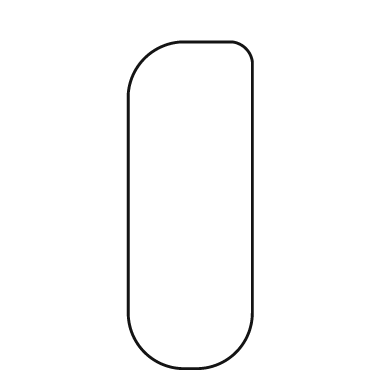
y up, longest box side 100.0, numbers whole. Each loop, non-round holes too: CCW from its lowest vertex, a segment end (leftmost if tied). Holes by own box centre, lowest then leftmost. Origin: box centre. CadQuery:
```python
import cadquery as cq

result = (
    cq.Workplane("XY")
    .moveTo(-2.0, -50.0)
    .lineTo(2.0, -50.0)
    .threePointArc((14.0, -45.0), (19.0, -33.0))
    .lineTo(19.0, 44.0)
    .threePointArc((17.0, 48.0), (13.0, 50.0))
    .lineTo(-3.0, 50.0)
    .threePointArc((-14.0, 45.0), (-19.0, 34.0))
    .lineTo(-19.0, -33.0)
    .threePointArc((-14.0, -45.0), (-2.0, -50.0))
    .close()
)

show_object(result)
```